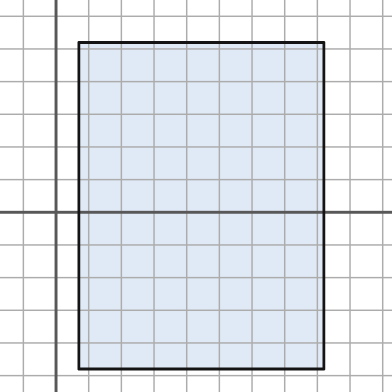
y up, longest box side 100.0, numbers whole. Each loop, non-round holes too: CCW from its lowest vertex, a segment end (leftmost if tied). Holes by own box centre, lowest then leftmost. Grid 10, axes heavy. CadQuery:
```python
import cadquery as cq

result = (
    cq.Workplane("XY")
    .moveTo(7.0, -48.0)
    .lineTo(82.0, -48.0)
    .lineTo(82.0, 52.0)
    .lineTo(7.0, 52.0)
    .close()
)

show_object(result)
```